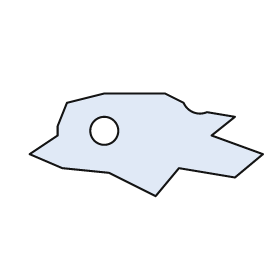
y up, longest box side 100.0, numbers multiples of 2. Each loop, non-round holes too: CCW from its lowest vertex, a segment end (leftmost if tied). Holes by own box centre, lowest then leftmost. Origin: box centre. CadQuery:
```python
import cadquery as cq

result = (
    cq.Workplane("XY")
    .moveTo(4.0, -22.0)
    .lineTo(14.0, -10.0)
    .lineTo(38.0, -14.0)
    .lineTo(50.0, -4.0)
    .lineTo(28.0, 4.0)
    .lineTo(38.0, 12.0)
    .lineTo(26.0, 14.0)
    .threePointArc((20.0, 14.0), (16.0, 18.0))
    .lineTo(8.0, 22.0)
    .lineTo(-18.0, 22.0)
    .lineTo(-34.0, 18.0)
    .lineTo(-38.0, 8.0)
    .lineTo(-38.0, 4.0)
    .lineTo(-50.0, -4.0)
    .lineTo(-36.0, -10.0)
    .lineTo(-16.0, -12.0)
    .close()
    .moveTo(-18.0, 6.0)
    .circle(6.0)
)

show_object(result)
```